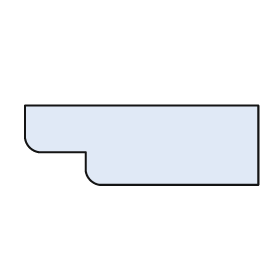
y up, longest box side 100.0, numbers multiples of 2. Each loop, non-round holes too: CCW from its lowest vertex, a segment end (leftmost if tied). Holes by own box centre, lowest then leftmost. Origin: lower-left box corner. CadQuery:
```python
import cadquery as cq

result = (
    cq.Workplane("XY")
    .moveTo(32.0, 0.0)
    .lineTo(100.0, 0.0)
    .lineTo(100.0, 34.0)
    .lineTo(0.0, 34.0)
    .lineTo(0.0, 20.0)
    .threePointArc((2.0, 16.0), (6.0, 14.0))
    .lineTo(26.0, 14.0)
    .lineTo(26.0, 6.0)
    .threePointArc((28.0, 2.0), (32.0, 0.0))
    .close()
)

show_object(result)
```